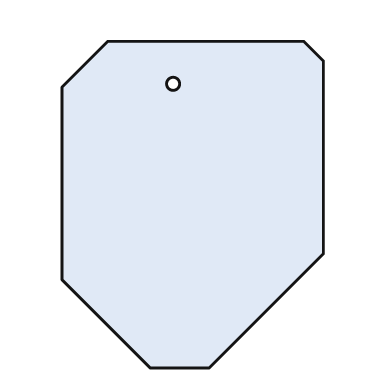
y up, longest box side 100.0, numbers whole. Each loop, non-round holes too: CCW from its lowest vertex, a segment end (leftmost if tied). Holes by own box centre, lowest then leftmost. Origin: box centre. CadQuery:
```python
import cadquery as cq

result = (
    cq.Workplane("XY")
    .moveTo(-13.0, -50.0)
    .lineTo(5.0, -50.0)
    .lineTo(40.0, -15.0)
    .lineTo(40.0, 44.0)
    .lineTo(34.0, 50.0)
    .lineTo(-26.0, 50.0)
    .lineTo(-40.0, 36.0)
    .lineTo(-40.0, -23.0)
    .close()
    .moveTo(-6.0, 37.0)
    .circle(2.0)
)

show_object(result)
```